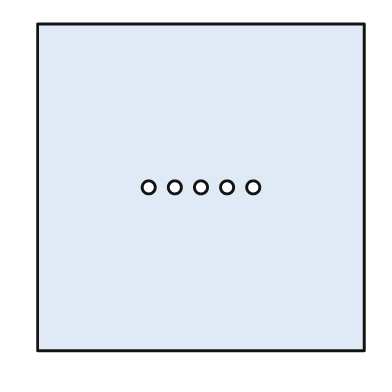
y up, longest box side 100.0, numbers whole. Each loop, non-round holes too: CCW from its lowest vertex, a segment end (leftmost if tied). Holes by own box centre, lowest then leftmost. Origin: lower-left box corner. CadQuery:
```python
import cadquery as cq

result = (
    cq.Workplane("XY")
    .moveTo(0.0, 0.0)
    .lineTo(100.0, 0.0)
    .lineTo(100.0, 100.0)
    .lineTo(0.0, 100.0)
    .close()
    .moveTo(34.0, 50.0)
    .circle(2.0)
    .moveTo(42.0, 50.0)
    .circle(2.0)
    .moveTo(50.0, 50.0)
    .circle(2.0)
    .moveTo(58.0, 50.0)
    .circle(2.0)
    .moveTo(66.0, 50.0)
    .circle(2.0)
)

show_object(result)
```